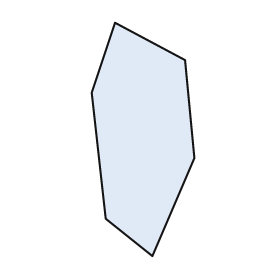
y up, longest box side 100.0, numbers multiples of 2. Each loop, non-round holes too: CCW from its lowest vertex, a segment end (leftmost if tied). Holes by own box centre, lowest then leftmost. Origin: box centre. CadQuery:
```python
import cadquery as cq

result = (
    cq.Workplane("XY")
    .moveTo(4.0, -50.0)
    .lineTo(22.0, -8.0)
    .lineTo(18.0, 34.0)
    .lineTo(-12.0, 50.0)
    .lineTo(-22.0, 20.0)
    .lineTo(-16.0, -34.0)
    .close()
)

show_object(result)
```